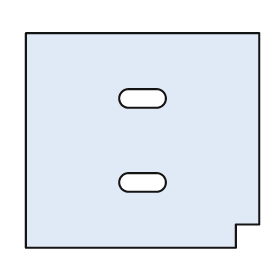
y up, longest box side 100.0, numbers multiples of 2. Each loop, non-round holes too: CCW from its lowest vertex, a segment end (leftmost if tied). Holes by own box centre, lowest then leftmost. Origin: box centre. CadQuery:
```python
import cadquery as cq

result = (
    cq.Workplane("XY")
    .moveTo(-50.0, -46.0)
    .lineTo(40.0, -46.0)
    .lineTo(40.0, -36.0)
    .lineTo(50.0, -36.0)
    .lineTo(50.0, 46.0)
    .lineTo(-50.0, 46.0)
    .close()
    .moveTo(-6.0, -22.0)
    .lineTo(6.0, -22.0)
    .threePointArc((10.0, -18.0), (6.0, -14.0))
    .lineTo(-6.0, -14.0)
    .threePointArc((-10.0, -18.0), (-6.0, -22.0))
    .close()
    .moveTo(-6.0, 14.0)
    .lineTo(6.0, 14.0)
    .threePointArc((10.0, 18.0), (6.0, 22.0))
    .lineTo(-6.0, 22.0)
    .threePointArc((-10.0, 18.0), (-6.0, 14.0))
    .close()
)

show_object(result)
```